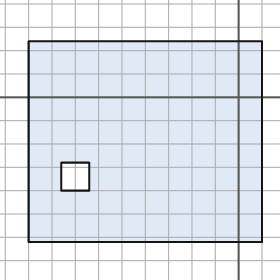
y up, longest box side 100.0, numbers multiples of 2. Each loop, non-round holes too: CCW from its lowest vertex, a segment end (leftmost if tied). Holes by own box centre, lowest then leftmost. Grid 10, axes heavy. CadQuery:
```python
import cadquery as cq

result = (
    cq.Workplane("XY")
    .moveTo(-90.0, -62.0)
    .lineTo(10.0, -62.0)
    .lineTo(10.0, 24.0)
    .lineTo(-90.0, 24.0)
    .close()
    .moveTo(-76.0, -40.0)
    .lineTo(-64.0, -40.0)
    .lineTo(-64.0, -28.0)
    .lineTo(-76.0, -28.0)
    .close()
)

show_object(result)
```